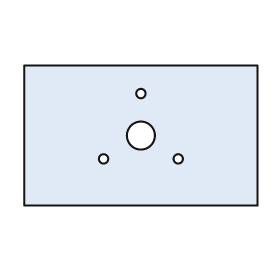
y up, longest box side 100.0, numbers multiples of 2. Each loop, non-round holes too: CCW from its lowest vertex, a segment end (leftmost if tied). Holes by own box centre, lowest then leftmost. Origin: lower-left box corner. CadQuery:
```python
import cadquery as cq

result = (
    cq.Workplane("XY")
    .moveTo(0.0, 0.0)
    .lineTo(100.0, 0.0)
    .lineTo(100.0, 60.0)
    .lineTo(0.0, 60.0)
    .close()
    .moveTo(34.0, 20.0)
    .circle(2.0)
    .moveTo(66.0, 20.0)
    .circle(2.0)
    .moveTo(50.0, 30.0)
    .circle(6.0)
    .moveTo(50.0, 48.0)
    .circle(2.0)
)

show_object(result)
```